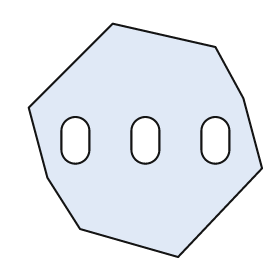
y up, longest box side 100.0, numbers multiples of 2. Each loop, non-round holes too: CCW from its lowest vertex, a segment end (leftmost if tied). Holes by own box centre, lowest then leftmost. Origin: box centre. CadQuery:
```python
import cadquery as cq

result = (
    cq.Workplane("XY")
    .moveTo(14.0, -50.0)
    .lineTo(50.0, -12.0)
    .lineTo(42.0, 18.0)
    .lineTo(30.0, 40.0)
    .lineTo(-14.0, 50.0)
    .lineTo(-50.0, 14.0)
    .lineTo(-42.0, -16.0)
    .lineTo(-28.0, -38.0)
    .close()
    .moveTo(-36.0, -4.0)
    .threePointArc((-30.0, -10.0), (-24.0, -4.0))
    .lineTo(-24.0, 4.0)
    .threePointArc((-30.0, 10.0), (-36.0, 4.0))
    .close()
    .moveTo(-6.0, -4.0)
    .threePointArc((0.0, -10.0), (6.0, -4.0))
    .lineTo(6.0, 4.0)
    .threePointArc((0.0, 10.0), (-6.0, 4.0))
    .close()
    .moveTo(24.0, -4.0)
    .threePointArc((30.0, -10.0), (36.0, -4.0))
    .lineTo(36.0, 4.0)
    .threePointArc((30.0, 10.0), (24.0, 4.0))
    .close()
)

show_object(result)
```